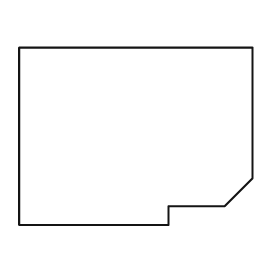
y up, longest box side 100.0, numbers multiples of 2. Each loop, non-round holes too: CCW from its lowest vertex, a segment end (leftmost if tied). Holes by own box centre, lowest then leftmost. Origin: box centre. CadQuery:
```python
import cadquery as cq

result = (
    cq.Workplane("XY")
    .moveTo(-50.0, -38.0)
    .lineTo(14.0, -38.0)
    .lineTo(14.0, -30.0)
    .lineTo(38.0, -30.0)
    .lineTo(50.0, -18.0)
    .lineTo(50.0, 38.0)
    .lineTo(-50.0, 38.0)
    .close()
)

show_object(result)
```